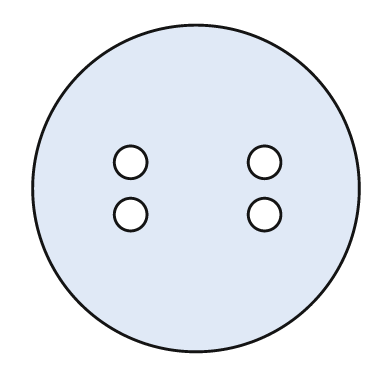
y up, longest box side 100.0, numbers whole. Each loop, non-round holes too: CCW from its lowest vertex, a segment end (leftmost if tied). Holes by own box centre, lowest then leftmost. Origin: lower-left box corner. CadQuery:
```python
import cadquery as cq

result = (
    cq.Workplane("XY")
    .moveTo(50.0, 50.0)
    .circle(50.0)
    .moveTo(30.0, 42.0)
    .circle(5.0)
    .moveTo(71.0, 42.0)
    .circle(5.0)
    .moveTo(30.0, 58.0)
    .circle(5.0)
    .moveTo(71.0, 58.0)
    .circle(5.0)
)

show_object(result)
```